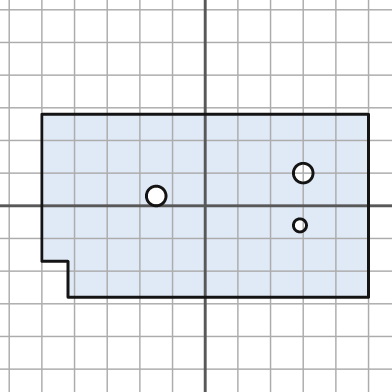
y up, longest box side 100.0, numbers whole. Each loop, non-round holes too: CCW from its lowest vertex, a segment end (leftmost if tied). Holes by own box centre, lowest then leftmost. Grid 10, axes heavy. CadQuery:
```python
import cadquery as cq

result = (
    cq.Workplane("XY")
    .moveTo(-42.0, -28.0)
    .lineTo(50.0, -28.0)
    .lineTo(50.0, 28.0)
    .lineTo(-50.0, 28.0)
    .lineTo(-50.0, -17.0)
    .lineTo(-42.0, -17.0)
    .close()
    .moveTo(29.0, -6.0)
    .circle(2.0)
    .moveTo(-15.0, 3.0)
    .circle(3.0)
    .moveTo(30.0, 10.0)
    .circle(3.0)
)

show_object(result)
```